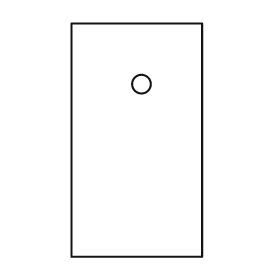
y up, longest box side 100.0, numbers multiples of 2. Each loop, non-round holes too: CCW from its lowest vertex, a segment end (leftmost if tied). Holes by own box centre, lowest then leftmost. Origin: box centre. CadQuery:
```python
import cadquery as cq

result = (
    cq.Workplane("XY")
    .moveTo(-28.0, -50.0)
    .lineTo(28.0, -50.0)
    .lineTo(28.0, 50.0)
    .lineTo(-28.0, 50.0)
    .close()
    .moveTo(2.0, 24.0)
    .circle(4.0)
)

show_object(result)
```